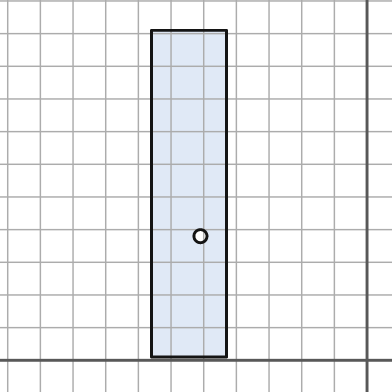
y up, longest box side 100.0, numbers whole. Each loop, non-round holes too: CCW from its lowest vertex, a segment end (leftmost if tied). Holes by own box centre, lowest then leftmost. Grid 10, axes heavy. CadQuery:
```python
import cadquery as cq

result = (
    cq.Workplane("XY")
    .moveTo(-66.0, 1.0)
    .lineTo(-43.0, 1.0)
    .lineTo(-43.0, 101.0)
    .lineTo(-66.0, 101.0)
    .close()
    .moveTo(-51.0, 38.0)
    .circle(2.0)
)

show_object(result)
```